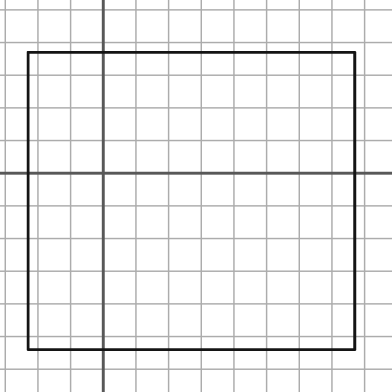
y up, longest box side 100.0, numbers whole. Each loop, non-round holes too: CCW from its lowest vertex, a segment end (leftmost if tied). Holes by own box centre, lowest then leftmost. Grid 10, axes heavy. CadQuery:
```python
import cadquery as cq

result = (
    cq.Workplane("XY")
    .moveTo(-23.0, -54.0)
    .lineTo(77.0, -54.0)
    .lineTo(77.0, 37.0)
    .lineTo(-23.0, 37.0)
    .close()
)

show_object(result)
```